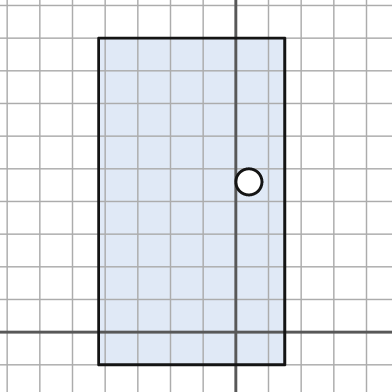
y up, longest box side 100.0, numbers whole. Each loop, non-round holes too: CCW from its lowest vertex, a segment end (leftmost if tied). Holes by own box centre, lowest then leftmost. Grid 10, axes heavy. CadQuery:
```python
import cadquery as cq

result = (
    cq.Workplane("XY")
    .moveTo(-42.0, -10.0)
    .lineTo(15.0, -10.0)
    .lineTo(15.0, 90.0)
    .lineTo(-42.0, 90.0)
    .close()
    .moveTo(4.0, 46.0)
    .circle(4.0)
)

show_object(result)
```